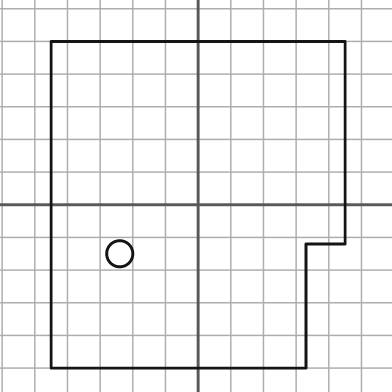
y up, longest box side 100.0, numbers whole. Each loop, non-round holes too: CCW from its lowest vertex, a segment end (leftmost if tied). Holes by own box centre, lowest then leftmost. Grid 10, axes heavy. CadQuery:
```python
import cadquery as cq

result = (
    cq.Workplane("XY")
    .moveTo(-45.0, -50.0)
    .lineTo(33.0, -50.0)
    .lineTo(33.0, -12.0)
    .lineTo(45.0, -12.0)
    .lineTo(45.0, 50.0)
    .lineTo(-45.0, 50.0)
    .close()
    .moveTo(-24.0, -15.0)
    .circle(4.0)
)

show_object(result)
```